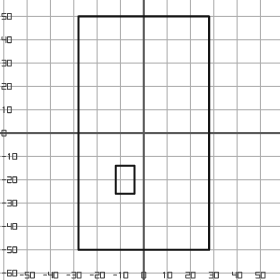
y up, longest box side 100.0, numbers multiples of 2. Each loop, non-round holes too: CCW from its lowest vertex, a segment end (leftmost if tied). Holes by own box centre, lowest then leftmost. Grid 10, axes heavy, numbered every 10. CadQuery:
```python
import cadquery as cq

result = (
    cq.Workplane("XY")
    .moveTo(-28.0, -50.0)
    .lineTo(28.0, -50.0)
    .lineTo(28.0, 50.0)
    .lineTo(-28.0, 50.0)
    .close()
    .moveTo(-12.0, -26.0)
    .lineTo(-4.0, -26.0)
    .lineTo(-4.0, -14.0)
    .lineTo(-12.0, -14.0)
    .close()
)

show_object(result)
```